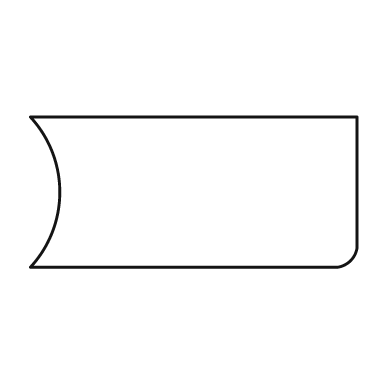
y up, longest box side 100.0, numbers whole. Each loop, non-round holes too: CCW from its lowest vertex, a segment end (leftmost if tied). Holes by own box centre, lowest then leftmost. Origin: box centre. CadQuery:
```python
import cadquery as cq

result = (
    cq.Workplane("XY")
    .moveTo(-50.0, -23.0)
    .lineTo(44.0, -23.0)
    .threePointArc((48.0, -21.0), (50.0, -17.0))
    .lineTo(50.0, 23.0)
    .lineTo(-50.0, 23.0)
    .threePointArc((-41.0, 0.0), (-50.0, -23.0))
    .close()
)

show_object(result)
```